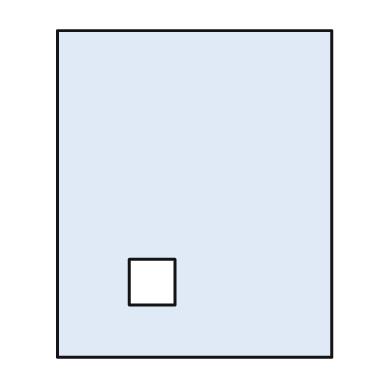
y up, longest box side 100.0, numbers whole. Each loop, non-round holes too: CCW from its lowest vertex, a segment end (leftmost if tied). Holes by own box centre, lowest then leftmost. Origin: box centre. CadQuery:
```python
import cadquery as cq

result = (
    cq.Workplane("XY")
    .moveTo(-42.0, -50.0)
    .lineTo(42.0, -50.0)
    .lineTo(42.0, 50.0)
    .lineTo(-42.0, 50.0)
    .close()
    .moveTo(-20.0, -34.0)
    .lineTo(-6.0, -34.0)
    .lineTo(-6.0, -20.0)
    .lineTo(-20.0, -20.0)
    .close()
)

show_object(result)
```